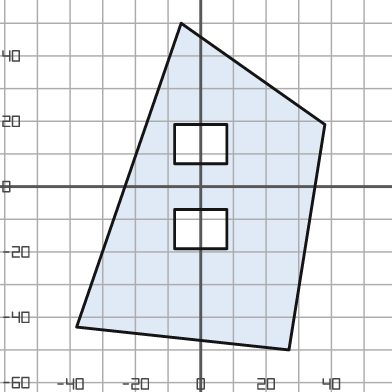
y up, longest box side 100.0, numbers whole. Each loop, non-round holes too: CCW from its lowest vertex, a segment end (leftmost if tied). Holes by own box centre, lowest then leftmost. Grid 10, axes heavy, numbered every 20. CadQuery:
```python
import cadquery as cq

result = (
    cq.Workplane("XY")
    .moveTo(27.0, -50.0)
    .lineTo(38.0, 19.0)
    .lineTo(-6.0, 50.0)
    .lineTo(-38.0, -43.0)
    .close()
    .moveTo(-8.0, -19.0)
    .lineTo(8.0, -19.0)
    .lineTo(8.0, -7.0)
    .lineTo(-8.0, -7.0)
    .close()
    .moveTo(-8.0, 7.0)
    .lineTo(8.0, 7.0)
    .lineTo(8.0, 19.0)
    .lineTo(-8.0, 19.0)
    .close()
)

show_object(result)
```